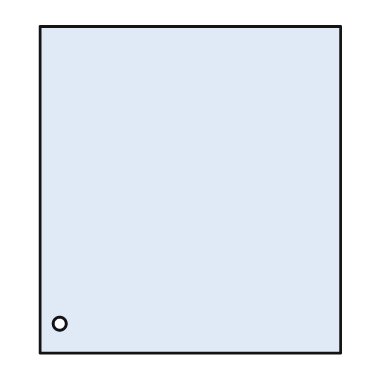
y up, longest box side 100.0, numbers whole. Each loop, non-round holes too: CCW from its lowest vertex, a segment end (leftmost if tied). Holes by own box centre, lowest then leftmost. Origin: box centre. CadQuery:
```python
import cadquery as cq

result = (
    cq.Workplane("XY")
    .moveTo(-46.0, -50.0)
    .lineTo(46.0, -50.0)
    .lineTo(46.0, 50.0)
    .lineTo(-46.0, 50.0)
    .close()
    .moveTo(-40.0, -41.0)
    .circle(2.0)
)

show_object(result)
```